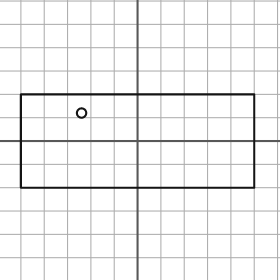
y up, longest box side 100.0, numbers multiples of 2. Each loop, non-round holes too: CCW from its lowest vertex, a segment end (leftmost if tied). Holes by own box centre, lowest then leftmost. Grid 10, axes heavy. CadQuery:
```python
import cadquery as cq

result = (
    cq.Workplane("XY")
    .moveTo(-50.0, -20.0)
    .lineTo(50.0, -20.0)
    .lineTo(50.0, 20.0)
    .lineTo(-50.0, 20.0)
    .close()
    .moveTo(-24.0, 12.0)
    .circle(2.0)
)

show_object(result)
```